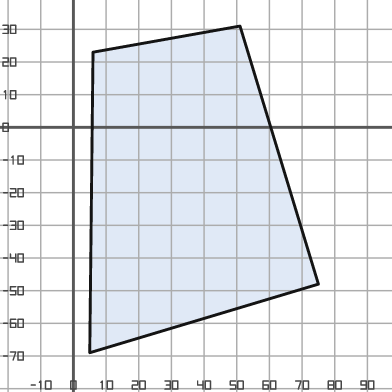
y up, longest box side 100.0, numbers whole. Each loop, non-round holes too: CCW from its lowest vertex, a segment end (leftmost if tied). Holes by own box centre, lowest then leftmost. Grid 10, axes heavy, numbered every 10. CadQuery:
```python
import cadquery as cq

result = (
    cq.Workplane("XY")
    .moveTo(5.0, -69.0)
    .lineTo(75.0, -48.0)
    .lineTo(51.0, 31.0)
    .lineTo(6.0, 23.0)
    .close()
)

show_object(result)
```